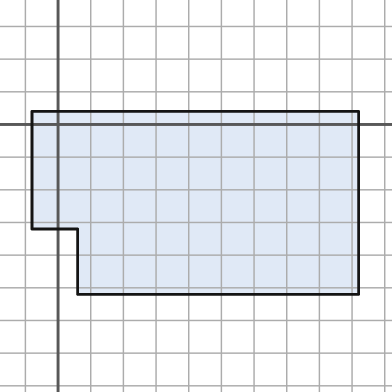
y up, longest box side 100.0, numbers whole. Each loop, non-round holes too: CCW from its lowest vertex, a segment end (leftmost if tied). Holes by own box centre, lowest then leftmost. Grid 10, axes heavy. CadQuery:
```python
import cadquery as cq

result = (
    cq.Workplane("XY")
    .moveTo(6.0, -52.0)
    .lineTo(92.0, -52.0)
    .lineTo(92.0, 4.0)
    .lineTo(-8.0, 4.0)
    .lineTo(-8.0, -32.0)
    .lineTo(6.0, -32.0)
    .close()
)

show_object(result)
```